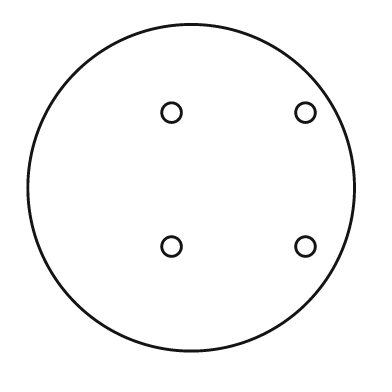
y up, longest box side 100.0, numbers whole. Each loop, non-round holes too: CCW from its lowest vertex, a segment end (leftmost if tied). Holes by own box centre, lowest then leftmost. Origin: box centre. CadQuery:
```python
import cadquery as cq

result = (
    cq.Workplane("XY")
    .moveTo(0.0, 0.0)
    .circle(50.0)
    .moveTo(-6.0, -18.0)
    .circle(3.0)
    .moveTo(35.0, -18.0)
    .circle(3.0)
    .moveTo(-6.0, 23.0)
    .circle(3.0)
    .moveTo(35.0, 23.0)
    .circle(3.0)
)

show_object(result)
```